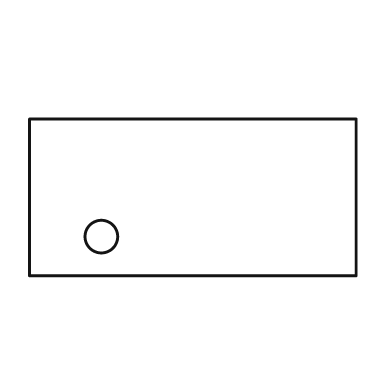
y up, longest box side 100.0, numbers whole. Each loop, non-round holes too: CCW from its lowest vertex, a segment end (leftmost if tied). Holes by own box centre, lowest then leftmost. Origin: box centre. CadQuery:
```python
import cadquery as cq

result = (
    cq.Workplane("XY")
    .moveTo(-50.0, -24.0)
    .lineTo(50.0, -24.0)
    .lineTo(50.0, 24.0)
    .lineTo(-50.0, 24.0)
    .close()
    .moveTo(-28.0, -12.0)
    .circle(5.0)
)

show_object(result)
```